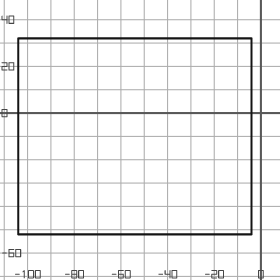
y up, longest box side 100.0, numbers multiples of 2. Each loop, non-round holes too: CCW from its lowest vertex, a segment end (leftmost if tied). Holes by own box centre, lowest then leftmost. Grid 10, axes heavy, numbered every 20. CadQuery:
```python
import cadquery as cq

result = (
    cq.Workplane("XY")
    .moveTo(-104.0, -52.0)
    .lineTo(-4.0, -52.0)
    .lineTo(-4.0, 32.0)
    .lineTo(-104.0, 32.0)
    .close()
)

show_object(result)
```